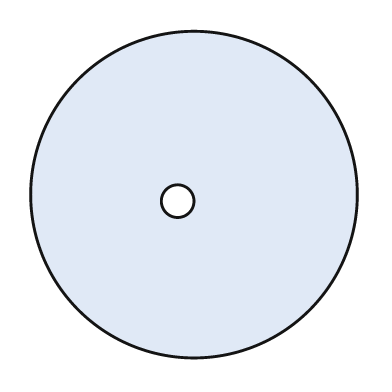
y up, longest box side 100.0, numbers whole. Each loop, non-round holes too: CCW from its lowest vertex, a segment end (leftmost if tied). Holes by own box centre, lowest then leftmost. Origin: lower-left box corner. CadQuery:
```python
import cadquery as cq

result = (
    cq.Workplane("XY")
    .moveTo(50.0, 50.0)
    .circle(50.0)
    .moveTo(45.0, 48.0)
    .circle(5.0)
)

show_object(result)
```